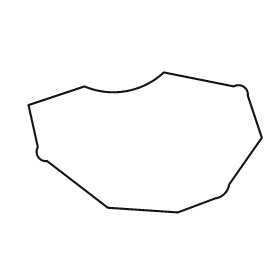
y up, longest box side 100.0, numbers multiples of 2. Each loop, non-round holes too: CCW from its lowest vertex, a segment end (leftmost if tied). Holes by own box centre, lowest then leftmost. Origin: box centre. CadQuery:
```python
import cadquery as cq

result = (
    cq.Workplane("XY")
    .moveTo(14.0, -30.0)
    .lineTo(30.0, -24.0)
    .threePointArc((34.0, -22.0), (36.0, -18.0))
    .lineTo(50.0, 2.0)
    .lineTo(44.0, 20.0)
    .threePointArc((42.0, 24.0), (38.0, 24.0))
    .lineTo(8.0, 30.0)
    .threePointArc((-8.0, 22.0), (-26.0, 24.0))
    .lineTo(-50.0, 16.0)
    .lineTo(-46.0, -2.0)
    .threePointArc((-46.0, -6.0), (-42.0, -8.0))
    .lineTo(-16.0, -28.0)
    .close()
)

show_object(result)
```